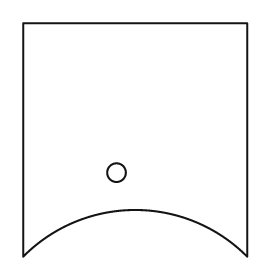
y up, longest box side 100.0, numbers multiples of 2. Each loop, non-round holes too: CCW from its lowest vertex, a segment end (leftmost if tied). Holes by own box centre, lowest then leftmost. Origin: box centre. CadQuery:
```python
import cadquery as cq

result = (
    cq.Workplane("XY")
    .moveTo(-48.0, -50.0)
    .threePointArc((0.0, -30.0), (48.0, -50.0))
    .lineTo(48.0, 50.0)
    .lineTo(-48.0, 50.0)
    .close()
    .moveTo(-8.0, -14.0)
    .circle(4.0)
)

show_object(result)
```